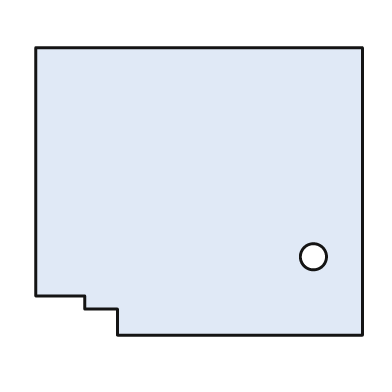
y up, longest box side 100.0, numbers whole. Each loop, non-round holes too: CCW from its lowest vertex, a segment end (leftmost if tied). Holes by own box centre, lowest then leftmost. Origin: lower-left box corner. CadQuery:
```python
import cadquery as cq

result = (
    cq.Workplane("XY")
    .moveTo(25.0, 0.0)
    .lineTo(100.0, 0.0)
    .lineTo(100.0, 88.0)
    .lineTo(0.0, 88.0)
    .lineTo(0.0, 12.0)
    .lineTo(15.0, 12.0)
    .lineTo(15.0, 8.0)
    .lineTo(25.0, 8.0)
    .close()
    .moveTo(85.0, 24.0)
    .circle(4.0)
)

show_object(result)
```